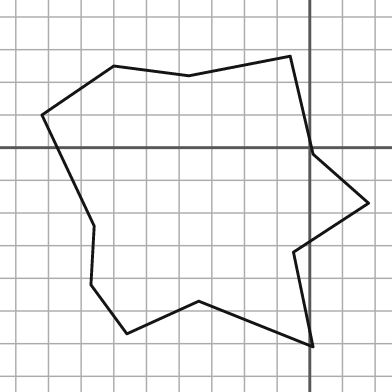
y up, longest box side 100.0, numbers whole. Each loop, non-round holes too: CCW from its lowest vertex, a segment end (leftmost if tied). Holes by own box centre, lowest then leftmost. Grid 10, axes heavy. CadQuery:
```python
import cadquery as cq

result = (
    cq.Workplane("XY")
    .moveTo(1.0, -61.0)
    .lineTo(-5.0, -32.0)
    .lineTo(18.0, -17.0)
    .lineTo(1.0, -2.0)
    .lineTo(-6.0, 28.0)
    .lineTo(-37.0, 22.0)
    .lineTo(-60.0, 25.0)
    .lineTo(-82.0, 10.0)
    .lineTo(-66.0, -24.0)
    .lineTo(-67.0, -42.0)
    .lineTo(-56.0, -57.0)
    .lineTo(-34.0, -47.0)
    .close()
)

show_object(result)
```